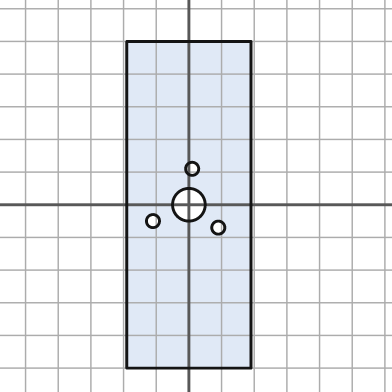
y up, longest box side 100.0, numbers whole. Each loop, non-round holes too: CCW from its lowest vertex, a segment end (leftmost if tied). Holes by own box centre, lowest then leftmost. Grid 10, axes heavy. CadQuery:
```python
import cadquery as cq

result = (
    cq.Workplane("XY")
    .moveTo(-19.0, -50.0)
    .lineTo(19.0, -50.0)
    .lineTo(19.0, 50.0)
    .lineTo(-19.0, 50.0)
    .close()
    .moveTo(9.0, -7.0)
    .circle(2.0)
    .moveTo(-11.0, -5.0)
    .circle(2.0)
    .moveTo(0.0, 0.0)
    .circle(5.0)
    .moveTo(1.0, 11.0)
    .circle(2.0)
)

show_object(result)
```